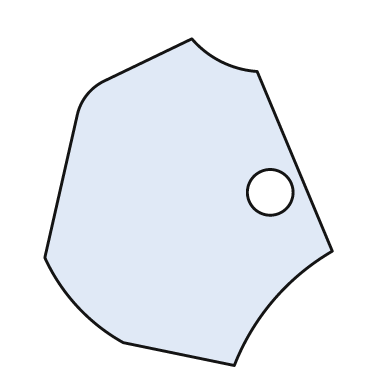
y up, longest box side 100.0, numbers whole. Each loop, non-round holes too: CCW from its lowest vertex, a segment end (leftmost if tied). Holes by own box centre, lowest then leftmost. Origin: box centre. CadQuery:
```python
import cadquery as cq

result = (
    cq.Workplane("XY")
    .moveTo(14.0, -50.0)
    .threePointArc((26.0, -30.0), (44.0, -15.0))
    .lineTo(21.0, 40.0)
    .threePointArc((10.0, 43.0), (1.0, 50.0))
    .lineTo(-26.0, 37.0)
    .threePointArc((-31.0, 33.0), (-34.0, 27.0))
    .lineTo(-44.0, -17.0)
    .threePointArc((-34.0, -32.0), (-20.0, -43.0))
    .close()
    .moveTo(25.0, 3.0)
    .circle(7.0)
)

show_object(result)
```